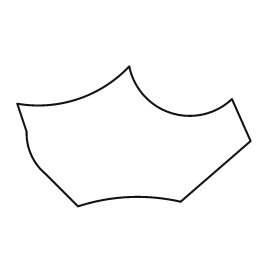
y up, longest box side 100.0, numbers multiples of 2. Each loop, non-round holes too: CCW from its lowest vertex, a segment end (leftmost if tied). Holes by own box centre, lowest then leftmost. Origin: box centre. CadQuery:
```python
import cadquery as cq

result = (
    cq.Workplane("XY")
    .moveTo(-24.0, -30.0)
    .threePointArc((-2.0, -26.0), (20.0, -28.0))
    .lineTo(50.0, -2.0)
    .lineTo(42.0, 16.0)
    .threePointArc((16.0, 10.0), (-2.0, 30.0))
    .threePointArc((-24.0, 16.0), (-50.0, 14.0))
    .lineTo(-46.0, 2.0)
    .threePointArc((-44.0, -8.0), (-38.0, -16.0))
    .close()
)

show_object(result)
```